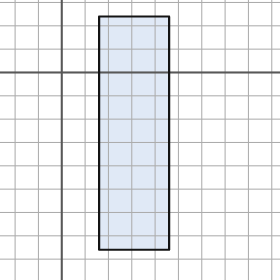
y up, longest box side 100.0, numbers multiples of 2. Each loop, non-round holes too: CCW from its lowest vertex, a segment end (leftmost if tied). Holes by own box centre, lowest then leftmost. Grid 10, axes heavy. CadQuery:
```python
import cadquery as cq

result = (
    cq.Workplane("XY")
    .moveTo(16.0, -76.0)
    .lineTo(46.0, -76.0)
    .lineTo(46.0, 24.0)
    .lineTo(16.0, 24.0)
    .close()
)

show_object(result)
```